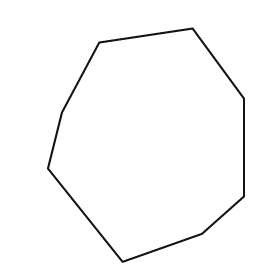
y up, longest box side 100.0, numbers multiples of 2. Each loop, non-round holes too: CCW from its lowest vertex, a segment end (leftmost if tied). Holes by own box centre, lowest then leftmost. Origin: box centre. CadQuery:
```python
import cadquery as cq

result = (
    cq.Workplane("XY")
    .moveTo(-10.0, -50.0)
    .lineTo(24.0, -38.0)
    .lineTo(42.0, -22.0)
    .lineTo(42.0, 20.0)
    .lineTo(20.0, 50.0)
    .lineTo(-20.0, 44.0)
    .lineTo(-36.0, 14.0)
    .lineTo(-42.0, -10.0)
    .close()
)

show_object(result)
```